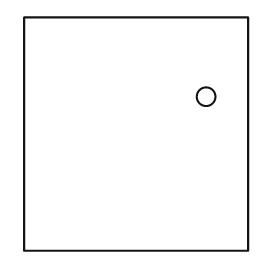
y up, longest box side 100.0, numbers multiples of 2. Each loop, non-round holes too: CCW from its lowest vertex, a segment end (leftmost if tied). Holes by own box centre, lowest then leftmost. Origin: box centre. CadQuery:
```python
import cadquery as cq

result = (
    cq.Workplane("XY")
    .moveTo(-48.0, -50.0)
    .lineTo(48.0, -50.0)
    .lineTo(48.0, 50.0)
    .lineTo(-48.0, 50.0)
    .close()
    .moveTo(30.0, 16.0)
    .circle(4.0)
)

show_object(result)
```